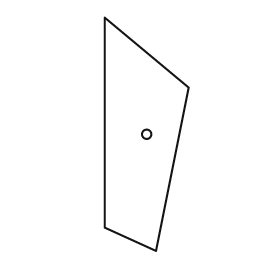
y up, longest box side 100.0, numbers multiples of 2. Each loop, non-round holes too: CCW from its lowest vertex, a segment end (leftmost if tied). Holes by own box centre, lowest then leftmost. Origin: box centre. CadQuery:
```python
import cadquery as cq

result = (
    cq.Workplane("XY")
    .moveTo(4.0, -50.0)
    .lineTo(18.0, 20.0)
    .lineTo(-18.0, 50.0)
    .lineTo(-18.0, -40.0)
    .close()
    .moveTo(0.0, 0.0)
    .circle(2.0)
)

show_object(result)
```